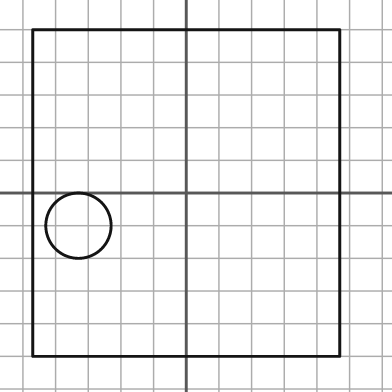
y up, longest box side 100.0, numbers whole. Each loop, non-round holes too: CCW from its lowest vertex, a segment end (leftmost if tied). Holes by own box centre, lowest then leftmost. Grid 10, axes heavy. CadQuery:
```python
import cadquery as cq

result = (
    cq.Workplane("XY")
    .moveTo(-47.0, -50.0)
    .lineTo(47.0, -50.0)
    .lineTo(47.0, 50.0)
    .lineTo(-47.0, 50.0)
    .close()
    .moveTo(-33.0, -10.0)
    .circle(10.0)
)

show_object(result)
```